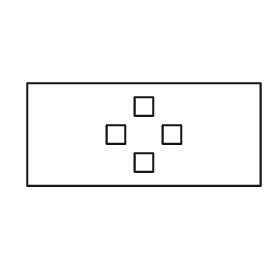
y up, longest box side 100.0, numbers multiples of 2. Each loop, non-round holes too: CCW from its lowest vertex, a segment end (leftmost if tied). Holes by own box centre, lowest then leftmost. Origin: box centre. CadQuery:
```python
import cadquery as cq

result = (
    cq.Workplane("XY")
    .moveTo(-50.0, -22.0)
    .lineTo(50.0, -22.0)
    .lineTo(50.0, 22.0)
    .lineTo(-50.0, 22.0)
    .close()
    .moveTo(-4.0, -16.0)
    .lineTo(4.0, -16.0)
    .lineTo(4.0, -8.0)
    .lineTo(-4.0, -8.0)
    .close()
    .moveTo(-16.0, -4.0)
    .lineTo(-8.0, -4.0)
    .lineTo(-8.0, 4.0)
    .lineTo(-16.0, 4.0)
    .close()
    .moveTo(8.0, -4.0)
    .lineTo(16.0, -4.0)
    .lineTo(16.0, 4.0)
    .lineTo(8.0, 4.0)
    .close()
    .moveTo(-4.0, 8.0)
    .lineTo(4.0, 8.0)
    .lineTo(4.0, 16.0)
    .lineTo(-4.0, 16.0)
    .close()
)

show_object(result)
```